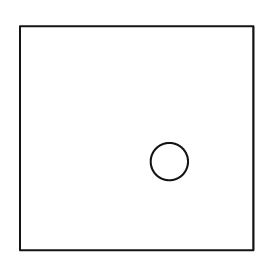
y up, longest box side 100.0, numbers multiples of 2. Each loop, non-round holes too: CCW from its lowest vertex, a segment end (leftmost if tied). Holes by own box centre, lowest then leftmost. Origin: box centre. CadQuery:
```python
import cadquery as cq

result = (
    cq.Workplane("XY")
    .moveTo(-50.0, -48.0)
    .lineTo(50.0, -48.0)
    .lineTo(50.0, 48.0)
    .lineTo(-50.0, 48.0)
    .close()
    .moveTo(14.0, -10.0)
    .circle(8.0)
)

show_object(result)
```